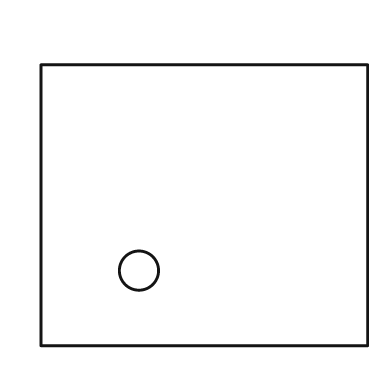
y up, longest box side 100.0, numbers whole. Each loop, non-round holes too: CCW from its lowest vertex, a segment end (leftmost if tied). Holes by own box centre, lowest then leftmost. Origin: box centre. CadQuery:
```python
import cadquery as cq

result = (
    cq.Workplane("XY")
    .moveTo(-50.0, -43.0)
    .lineTo(50.0, -43.0)
    .lineTo(50.0, 43.0)
    .lineTo(-50.0, 43.0)
    .close()
    .moveTo(-20.0, -20.0)
    .circle(6.0)
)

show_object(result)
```